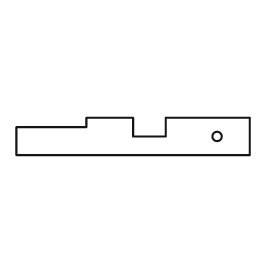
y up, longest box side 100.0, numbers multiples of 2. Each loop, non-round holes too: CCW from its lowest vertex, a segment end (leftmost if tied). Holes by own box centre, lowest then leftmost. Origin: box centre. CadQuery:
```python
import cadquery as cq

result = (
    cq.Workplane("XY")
    .moveTo(-50.0, -8.0)
    .lineTo(50.0, -8.0)
    .lineTo(50.0, 8.0)
    .lineTo(14.0, 8.0)
    .lineTo(14.0, 0.0)
    .lineTo(0.0, 0.0)
    .lineTo(0.0, 8.0)
    .lineTo(-20.0, 8.0)
    .lineTo(-20.0, 4.0)
    .lineTo(-50.0, 4.0)
    .close()
    .moveTo(36.0, 0.0)
    .circle(2.0)
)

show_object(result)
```